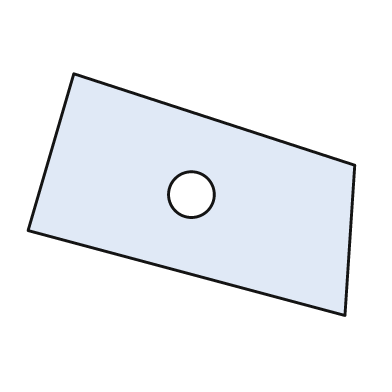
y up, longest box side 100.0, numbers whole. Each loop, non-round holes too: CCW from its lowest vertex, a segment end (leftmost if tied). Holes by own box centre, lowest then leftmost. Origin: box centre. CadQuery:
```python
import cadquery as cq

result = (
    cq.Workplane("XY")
    .moveTo(47.0, -37.0)
    .lineTo(50.0, 9.0)
    .lineTo(-36.0, 37.0)
    .lineTo(-50.0, -11.0)
    .close()
    .moveTo(0.0, 0.0)
    .circle(7.0)
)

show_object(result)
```